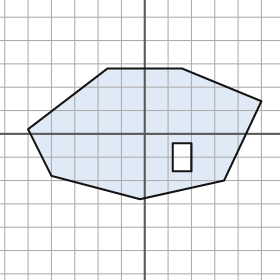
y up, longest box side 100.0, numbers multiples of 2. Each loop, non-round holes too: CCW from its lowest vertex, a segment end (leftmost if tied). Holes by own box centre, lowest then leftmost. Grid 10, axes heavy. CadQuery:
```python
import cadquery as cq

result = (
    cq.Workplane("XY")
    .moveTo(-2.0, -28.0)
    .lineTo(34.0, -20.0)
    .lineTo(50.0, 14.0)
    .lineTo(16.0, 28.0)
    .lineTo(-16.0, 28.0)
    .lineTo(-50.0, 2.0)
    .lineTo(-40.0, -18.0)
    .close()
    .moveTo(12.0, -16.0)
    .lineTo(20.0, -16.0)
    .lineTo(20.0, -4.0)
    .lineTo(12.0, -4.0)
    .close()
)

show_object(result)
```